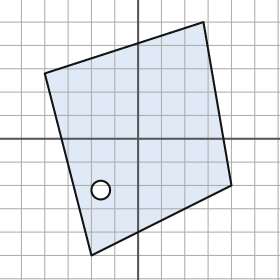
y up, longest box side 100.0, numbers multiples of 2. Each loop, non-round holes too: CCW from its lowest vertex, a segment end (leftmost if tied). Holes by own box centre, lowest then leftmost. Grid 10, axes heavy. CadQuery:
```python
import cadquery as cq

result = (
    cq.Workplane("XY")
    .moveTo(-20.0, -50.0)
    .lineTo(40.0, -20.0)
    .lineTo(28.0, 50.0)
    .lineTo(-40.0, 28.0)
    .close()
    .moveTo(-16.0, -22.0)
    .circle(4.0)
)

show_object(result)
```